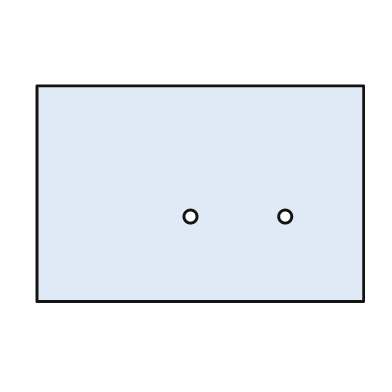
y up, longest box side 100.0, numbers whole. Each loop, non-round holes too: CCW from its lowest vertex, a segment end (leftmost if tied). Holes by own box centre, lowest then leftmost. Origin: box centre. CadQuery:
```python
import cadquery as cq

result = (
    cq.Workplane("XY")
    .moveTo(-50.0, -33.0)
    .lineTo(50.0, -33.0)
    .lineTo(50.0, 33.0)
    .lineTo(-50.0, 33.0)
    .close()
    .moveTo(-3.0, -7.0)
    .circle(2.0)
    .moveTo(26.0, -7.0)
    .circle(2.0)
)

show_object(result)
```